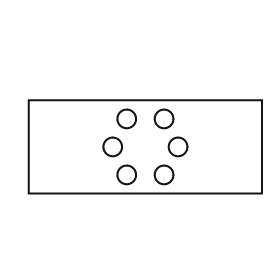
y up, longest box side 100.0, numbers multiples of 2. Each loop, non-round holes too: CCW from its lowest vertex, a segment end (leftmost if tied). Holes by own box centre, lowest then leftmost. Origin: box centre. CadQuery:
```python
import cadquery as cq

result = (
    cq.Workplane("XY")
    .moveTo(-50.0, -20.0)
    .lineTo(50.0, -20.0)
    .lineTo(50.0, 20.0)
    .lineTo(-50.0, 20.0)
    .close()
    .moveTo(-8.0, -12.0)
    .circle(4.0)
    .moveTo(8.0, -12.0)
    .circle(4.0)
    .moveTo(-14.0, 0.0)
    .circle(4.0)
    .moveTo(14.0, 0.0)
    .circle(4.0)
    .moveTo(-8.0, 12.0)
    .circle(4.0)
    .moveTo(8.0, 12.0)
    .circle(4.0)
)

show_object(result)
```